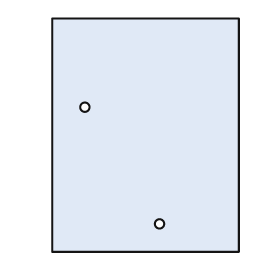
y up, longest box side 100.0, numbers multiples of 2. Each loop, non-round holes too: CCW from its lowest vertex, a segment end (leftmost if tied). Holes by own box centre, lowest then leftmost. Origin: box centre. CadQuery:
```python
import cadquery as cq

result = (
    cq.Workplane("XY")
    .moveTo(-40.0, -50.0)
    .lineTo(40.0, -50.0)
    .lineTo(40.0, 50.0)
    .lineTo(-40.0, 50.0)
    .close()
    .moveTo(6.0, -38.0)
    .circle(2.0)
    .moveTo(-26.0, 12.0)
    .circle(2.0)
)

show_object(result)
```